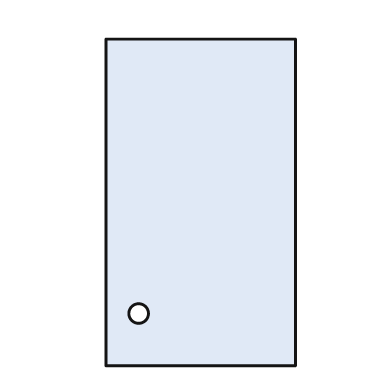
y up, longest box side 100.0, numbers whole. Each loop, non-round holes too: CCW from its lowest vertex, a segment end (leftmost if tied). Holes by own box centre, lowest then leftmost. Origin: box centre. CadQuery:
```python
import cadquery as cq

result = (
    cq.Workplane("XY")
    .moveTo(-29.0, -50.0)
    .lineTo(29.0, -50.0)
    .lineTo(29.0, 50.0)
    .lineTo(-29.0, 50.0)
    .close()
    .moveTo(-19.0, -34.0)
    .circle(3.0)
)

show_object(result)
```